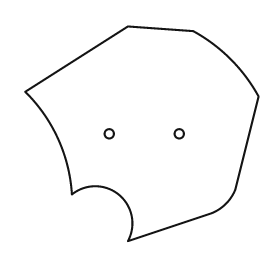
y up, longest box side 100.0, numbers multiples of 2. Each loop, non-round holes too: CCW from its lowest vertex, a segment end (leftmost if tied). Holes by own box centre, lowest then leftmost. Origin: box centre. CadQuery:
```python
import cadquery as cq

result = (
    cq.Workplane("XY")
    .moveTo(-6.0, -46.0)
    .lineTo(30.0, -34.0)
    .threePointArc((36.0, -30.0), (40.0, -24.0))
    .lineTo(50.0, 16.0)
    .threePointArc((38.0, 32.0), (22.0, 44.0))
    .lineTo(-6.0, 46.0)
    .lineTo(-50.0, 18.0)
    .threePointArc((-36.0, -2.0), (-30.0, -26.0))
    .threePointArc((-10.0, -26.0), (-6.0, -46.0))
    .close()
    .moveTo(-14.0, 0.0)
    .circle(2.0)
    .moveTo(16.0, 0.0)
    .circle(2.0)
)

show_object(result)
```